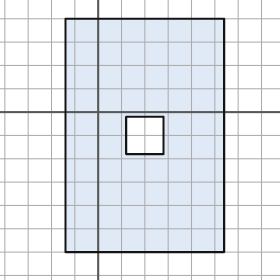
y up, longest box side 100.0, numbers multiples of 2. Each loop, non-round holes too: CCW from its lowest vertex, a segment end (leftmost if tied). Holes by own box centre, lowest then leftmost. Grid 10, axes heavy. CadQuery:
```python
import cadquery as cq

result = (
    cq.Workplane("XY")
    .moveTo(-14.0, -60.0)
    .lineTo(54.0, -60.0)
    .lineTo(54.0, 40.0)
    .lineTo(-14.0, 40.0)
    .close()
    .moveTo(12.0, -18.0)
    .lineTo(28.0, -18.0)
    .lineTo(28.0, -2.0)
    .lineTo(12.0, -2.0)
    .close()
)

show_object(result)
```